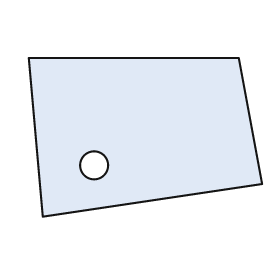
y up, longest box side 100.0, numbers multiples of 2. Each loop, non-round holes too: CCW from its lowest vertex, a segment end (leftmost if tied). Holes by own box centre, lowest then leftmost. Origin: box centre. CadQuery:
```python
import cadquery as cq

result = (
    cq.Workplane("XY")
    .moveTo(-44.0, -34.0)
    .lineTo(50.0, -20.0)
    .lineTo(40.0, 34.0)
    .lineTo(-50.0, 34.0)
    .close()
    .moveTo(-22.0, -12.0)
    .circle(6.0)
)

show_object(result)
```